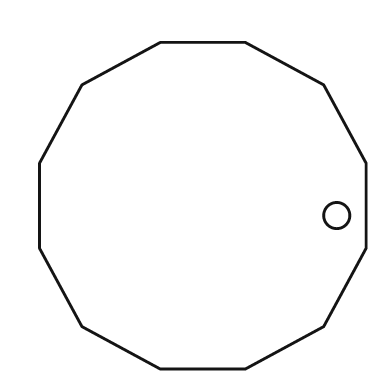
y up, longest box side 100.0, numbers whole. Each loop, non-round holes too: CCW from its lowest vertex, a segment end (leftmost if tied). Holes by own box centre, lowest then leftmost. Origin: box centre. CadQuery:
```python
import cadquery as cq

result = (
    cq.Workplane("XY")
    .moveTo(-13.0, -50.0)
    .lineTo(13.0, -50.0)
    .lineTo(37.0, -37.0)
    .lineTo(50.0, -13.0)
    .lineTo(50.0, 13.0)
    .lineTo(37.0, 37.0)
    .lineTo(13.0, 50.0)
    .lineTo(-13.0, 50.0)
    .lineTo(-37.0, 37.0)
    .lineTo(-50.0, 13.0)
    .lineTo(-50.0, -13.0)
    .lineTo(-37.0, -37.0)
    .close()
    .moveTo(41.0, -3.0)
    .circle(4.0)
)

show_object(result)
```